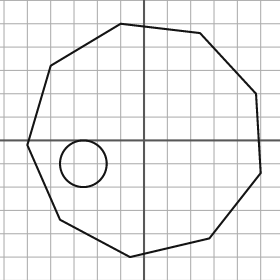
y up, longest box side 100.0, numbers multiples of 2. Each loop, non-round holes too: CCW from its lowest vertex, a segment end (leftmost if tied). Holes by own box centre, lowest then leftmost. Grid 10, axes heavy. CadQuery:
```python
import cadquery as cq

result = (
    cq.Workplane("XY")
    .moveTo(-6.0, -50.0)
    .lineTo(28.0, -42.0)
    .lineTo(50.0, -14.0)
    .lineTo(48.0, 20.0)
    .lineTo(24.0, 46.0)
    .lineTo(-10.0, 50.0)
    .lineTo(-40.0, 32.0)
    .lineTo(-50.0, -2.0)
    .lineTo(-36.0, -34.0)
    .close()
    .moveTo(-26.0, -10.0)
    .circle(10.0)
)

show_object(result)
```